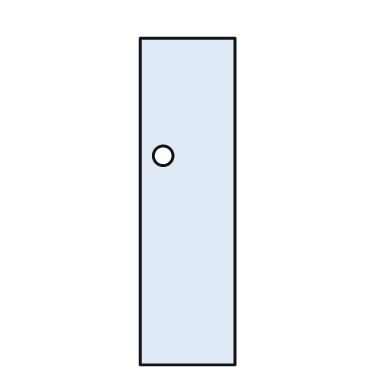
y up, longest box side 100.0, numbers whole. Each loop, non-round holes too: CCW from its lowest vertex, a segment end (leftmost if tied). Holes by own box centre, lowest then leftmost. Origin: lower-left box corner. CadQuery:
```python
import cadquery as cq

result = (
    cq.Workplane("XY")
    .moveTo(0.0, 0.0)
    .lineTo(29.0, 0.0)
    .lineTo(29.0, 100.0)
    .lineTo(0.0, 100.0)
    .close()
    .moveTo(7.0, 64.0)
    .circle(3.0)
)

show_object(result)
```